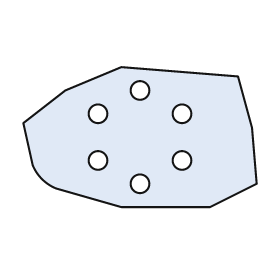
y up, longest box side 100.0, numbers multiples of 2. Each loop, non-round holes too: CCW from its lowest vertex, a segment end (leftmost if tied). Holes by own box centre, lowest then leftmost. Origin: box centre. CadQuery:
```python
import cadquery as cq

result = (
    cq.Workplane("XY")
    .moveTo(-8.0, -30.0)
    .lineTo(30.0, -30.0)
    .lineTo(50.0, -20.0)
    .lineTo(48.0, 4.0)
    .lineTo(42.0, 26.0)
    .lineTo(-8.0, 30.0)
    .lineTo(-32.0, 20.0)
    .lineTo(-50.0, 6.0)
    .lineTo(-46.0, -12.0)
    .threePointArc((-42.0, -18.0), (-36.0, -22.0))
    .close()
    .moveTo(0.0, -20.0)
    .circle(4.0)
    .moveTo(-18.0, -10.0)
    .circle(4.0)
    .moveTo(18.0, -10.0)
    .circle(4.0)
    .moveTo(-18.0, 10.0)
    .circle(4.0)
    .moveTo(18.0, 10.0)
    .circle(4.0)
    .moveTo(0.0, 20.0)
    .circle(4.0)
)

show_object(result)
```